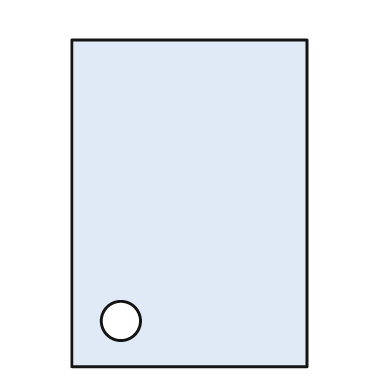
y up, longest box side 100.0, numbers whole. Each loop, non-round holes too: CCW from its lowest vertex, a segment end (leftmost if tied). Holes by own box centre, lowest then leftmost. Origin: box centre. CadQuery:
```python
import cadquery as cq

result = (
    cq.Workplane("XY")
    .moveTo(-36.0, -50.0)
    .lineTo(36.0, -50.0)
    .lineTo(36.0, 50.0)
    .lineTo(-36.0, 50.0)
    .close()
    .moveTo(-21.0, -36.0)
    .circle(6.0)
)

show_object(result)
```